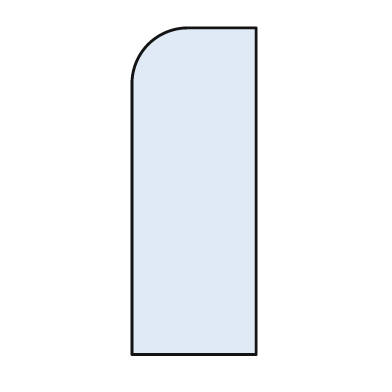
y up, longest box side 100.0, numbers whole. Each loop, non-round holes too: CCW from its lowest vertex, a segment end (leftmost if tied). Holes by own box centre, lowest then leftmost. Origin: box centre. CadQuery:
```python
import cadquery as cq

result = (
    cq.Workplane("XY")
    .moveTo(-19.0, -50.0)
    .lineTo(19.0, -50.0)
    .lineTo(19.0, 50.0)
    .lineTo(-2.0, 50.0)
    .threePointArc((-14.0, 45.0), (-19.0, 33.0))
    .close()
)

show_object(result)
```